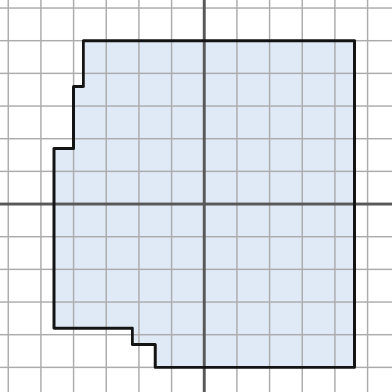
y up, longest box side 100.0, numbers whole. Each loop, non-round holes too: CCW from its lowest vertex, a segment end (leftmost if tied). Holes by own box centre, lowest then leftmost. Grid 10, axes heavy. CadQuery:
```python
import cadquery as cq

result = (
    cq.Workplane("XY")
    .moveTo(-15.0, -50.0)
    .lineTo(46.0, -50.0)
    .lineTo(46.0, 50.0)
    .lineTo(-37.0, 50.0)
    .lineTo(-37.0, 36.0)
    .lineTo(-40.0, 36.0)
    .lineTo(-40.0, 17.0)
    .lineTo(-46.0, 17.0)
    .lineTo(-46.0, -38.0)
    .lineTo(-22.0, -38.0)
    .lineTo(-22.0, -43.0)
    .lineTo(-15.0, -43.0)
    .close()
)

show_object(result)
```